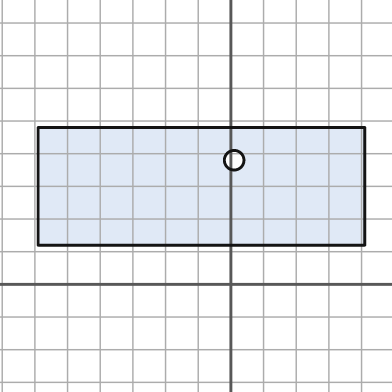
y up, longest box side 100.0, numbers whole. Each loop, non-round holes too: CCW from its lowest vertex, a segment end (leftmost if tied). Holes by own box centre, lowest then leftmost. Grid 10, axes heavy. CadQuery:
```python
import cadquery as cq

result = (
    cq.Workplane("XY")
    .moveTo(-59.0, 12.0)
    .lineTo(41.0, 12.0)
    .lineTo(41.0, 48.0)
    .lineTo(-59.0, 48.0)
    .close()
    .moveTo(1.0, 38.0)
    .circle(3.0)
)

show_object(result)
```